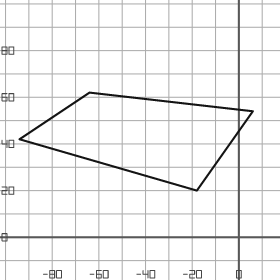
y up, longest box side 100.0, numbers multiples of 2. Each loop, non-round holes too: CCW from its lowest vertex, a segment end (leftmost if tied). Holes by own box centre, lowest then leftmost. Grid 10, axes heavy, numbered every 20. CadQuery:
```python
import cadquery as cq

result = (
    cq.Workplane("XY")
    .moveTo(-18.0, 20.0)
    .lineTo(6.0, 54.0)
    .lineTo(-64.0, 62.0)
    .lineTo(-94.0, 42.0)
    .close()
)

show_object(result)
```